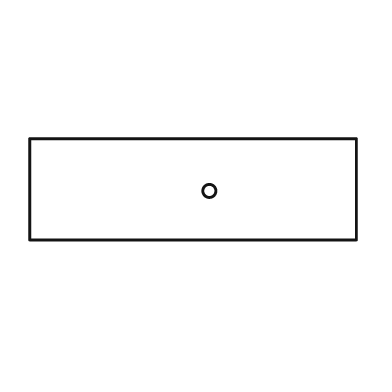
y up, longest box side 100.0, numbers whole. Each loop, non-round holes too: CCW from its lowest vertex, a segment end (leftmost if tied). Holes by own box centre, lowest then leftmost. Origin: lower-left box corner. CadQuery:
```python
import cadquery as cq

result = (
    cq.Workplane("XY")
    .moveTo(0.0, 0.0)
    .lineTo(100.0, 0.0)
    .lineTo(100.0, 31.0)
    .lineTo(0.0, 31.0)
    .close()
    .moveTo(55.0, 15.0)
    .circle(2.0)
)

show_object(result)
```